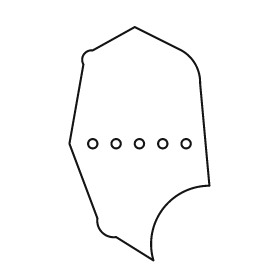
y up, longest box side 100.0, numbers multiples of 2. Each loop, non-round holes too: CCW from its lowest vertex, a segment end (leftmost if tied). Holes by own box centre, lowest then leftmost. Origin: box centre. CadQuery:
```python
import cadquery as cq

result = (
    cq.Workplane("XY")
    .moveTo(6.0, -50.0)
    .threePointArc((10.0, -28.0), (30.0, -18.0))
    .lineTo(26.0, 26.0)
    .threePointArc((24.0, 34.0), (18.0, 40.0))
    .lineTo(-2.0, 50.0)
    .lineTo(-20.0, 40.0)
    .threePointArc((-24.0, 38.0), (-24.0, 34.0))
    .lineTo(-30.0, 0.0)
    .lineTo(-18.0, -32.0)
    .threePointArc((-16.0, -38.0), (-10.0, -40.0))
    .close()
    .moveTo(-20.0, 0.0)
    .circle(2.0)
    .moveTo(-10.0, 0.0)
    .circle(2.0)
    .moveTo(0.0, 0.0)
    .circle(2.0)
    .moveTo(10.0, 0.0)
    .circle(2.0)
    .moveTo(20.0, 0.0)
    .circle(2.0)
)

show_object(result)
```